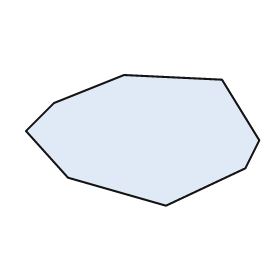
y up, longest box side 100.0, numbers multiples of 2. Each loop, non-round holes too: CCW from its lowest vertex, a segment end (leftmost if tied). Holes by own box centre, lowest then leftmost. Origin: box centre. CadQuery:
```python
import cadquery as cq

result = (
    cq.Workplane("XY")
    .moveTo(10.0, -28.0)
    .lineTo(44.0, -12.0)
    .lineTo(50.0, 0.0)
    .lineTo(34.0, 26.0)
    .lineTo(-8.0, 28.0)
    .lineTo(-38.0, 16.0)
    .lineTo(-50.0, 4.0)
    .lineTo(-32.0, -16.0)
    .close()
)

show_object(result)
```